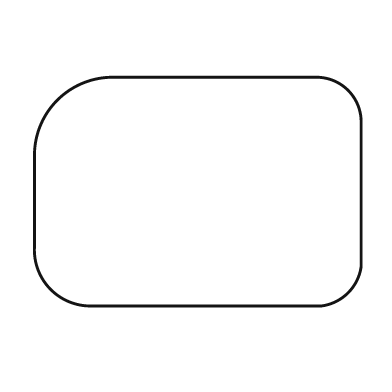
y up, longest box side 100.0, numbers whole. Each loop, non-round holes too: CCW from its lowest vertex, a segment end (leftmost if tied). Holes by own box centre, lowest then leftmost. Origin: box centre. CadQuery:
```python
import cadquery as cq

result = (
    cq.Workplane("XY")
    .moveTo(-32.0, -35.0)
    .lineTo(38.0, -35.0)
    .threePointArc((46.0, -31.0), (50.0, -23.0))
    .lineTo(50.0, 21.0)
    .threePointArc((46.0, 31.0), (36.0, 35.0))
    .lineTo(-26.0, 35.0)
    .threePointArc((-43.0, 28.0), (-50.0, 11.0))
    .lineTo(-50.0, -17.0)
    .threePointArc((-45.0, -30.0), (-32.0, -35.0))
    .close()
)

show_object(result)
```